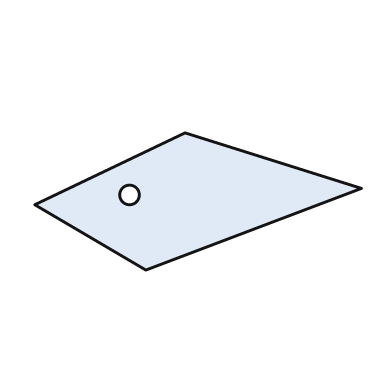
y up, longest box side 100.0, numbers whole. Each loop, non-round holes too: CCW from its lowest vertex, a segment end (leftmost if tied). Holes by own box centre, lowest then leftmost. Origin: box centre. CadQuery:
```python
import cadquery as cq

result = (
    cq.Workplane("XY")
    .moveTo(-16.0, -21.0)
    .lineTo(50.0, 4.0)
    .lineTo(-4.0, 21.0)
    .lineTo(-50.0, -1.0)
    .close()
    .moveTo(-21.0, 2.0)
    .circle(3.0)
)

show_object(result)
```